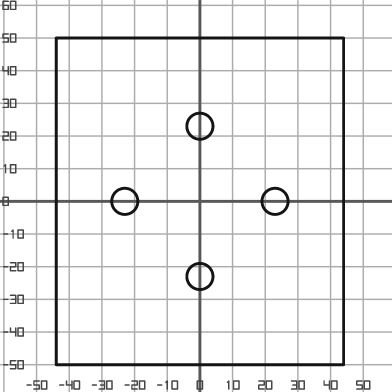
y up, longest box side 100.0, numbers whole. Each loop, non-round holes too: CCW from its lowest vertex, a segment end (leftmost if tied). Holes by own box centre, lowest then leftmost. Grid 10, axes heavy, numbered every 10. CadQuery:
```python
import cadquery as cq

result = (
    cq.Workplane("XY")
    .moveTo(-44.0, -50.0)
    .lineTo(44.0, -50.0)
    .lineTo(44.0, 50.0)
    .lineTo(-44.0, 50.0)
    .close()
    .moveTo(0.0, -23.0)
    .circle(4.0)
    .moveTo(-23.0, 0.0)
    .circle(4.0)
    .moveTo(23.0, 0.0)
    .circle(4.0)
    .moveTo(0.0, 23.0)
    .circle(4.0)
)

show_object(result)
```